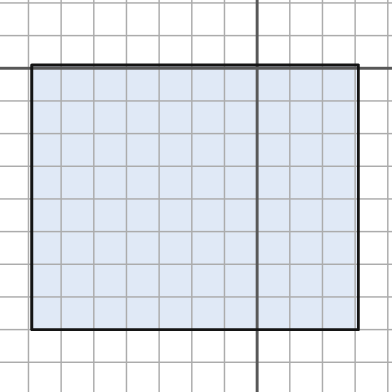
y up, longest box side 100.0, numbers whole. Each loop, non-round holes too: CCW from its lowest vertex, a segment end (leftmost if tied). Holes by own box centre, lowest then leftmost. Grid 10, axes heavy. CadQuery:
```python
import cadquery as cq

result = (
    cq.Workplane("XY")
    .moveTo(-69.0, -80.0)
    .lineTo(31.0, -80.0)
    .lineTo(31.0, 1.0)
    .lineTo(-69.0, 1.0)
    .close()
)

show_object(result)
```